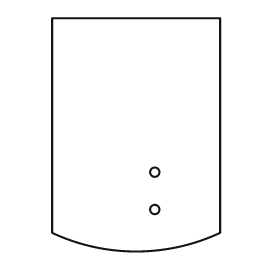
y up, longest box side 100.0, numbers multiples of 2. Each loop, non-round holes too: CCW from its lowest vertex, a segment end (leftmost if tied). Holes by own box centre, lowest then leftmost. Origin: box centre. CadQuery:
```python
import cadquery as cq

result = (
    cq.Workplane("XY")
    .moveTo(-36.0, -42.0)
    .threePointArc((0.0, -50.0), (36.0, -42.0))
    .lineTo(36.0, 50.0)
    .lineTo(-36.0, 50.0)
    .close()
    .moveTo(8.0, -32.0)
    .circle(2.0)
    .moveTo(8.0, -16.0)
    .circle(2.0)
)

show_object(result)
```